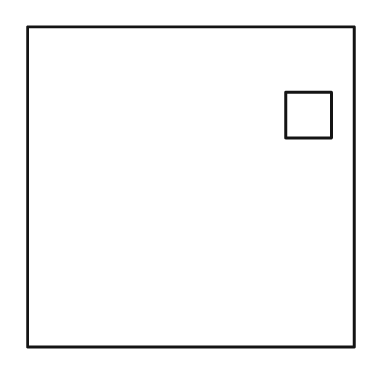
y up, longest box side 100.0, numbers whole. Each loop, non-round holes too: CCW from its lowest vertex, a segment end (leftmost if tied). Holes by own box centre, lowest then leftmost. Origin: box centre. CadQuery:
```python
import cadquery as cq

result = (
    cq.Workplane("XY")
    .moveTo(-50.0, -49.0)
    .lineTo(50.0, -49.0)
    .lineTo(50.0, 49.0)
    .lineTo(-50.0, 49.0)
    .close()
    .moveTo(29.0, 15.0)
    .lineTo(43.0, 15.0)
    .lineTo(43.0, 29.0)
    .lineTo(29.0, 29.0)
    .close()
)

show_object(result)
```